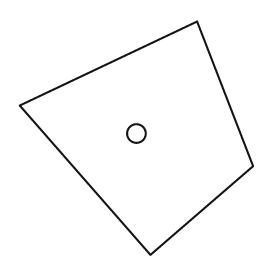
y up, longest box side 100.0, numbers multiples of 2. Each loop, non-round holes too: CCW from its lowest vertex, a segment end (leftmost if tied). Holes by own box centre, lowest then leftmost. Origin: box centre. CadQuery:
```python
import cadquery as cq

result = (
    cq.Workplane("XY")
    .moveTo(6.0, -50.0)
    .lineTo(50.0, -12.0)
    .lineTo(26.0, 50.0)
    .lineTo(-50.0, 14.0)
    .close()
    .moveTo(0.0, 2.0)
    .circle(4.0)
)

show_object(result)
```